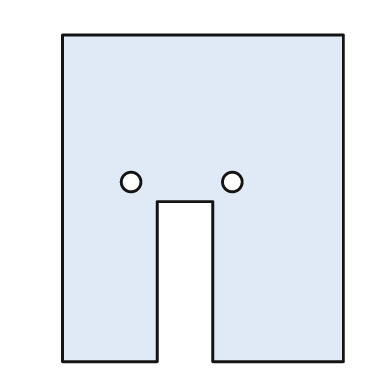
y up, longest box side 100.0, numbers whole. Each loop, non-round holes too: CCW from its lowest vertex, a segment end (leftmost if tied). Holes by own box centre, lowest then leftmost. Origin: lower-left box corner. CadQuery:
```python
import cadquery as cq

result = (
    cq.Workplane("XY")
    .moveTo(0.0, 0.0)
    .lineTo(29.0, 0.0)
    .lineTo(29.0, 49.0)
    .lineTo(46.0, 49.0)
    .lineTo(46.0, 0.0)
    .lineTo(86.0, 0.0)
    .lineTo(86.0, 100.0)
    .lineTo(0.0, 100.0)
    .close()
    .moveTo(21.0, 55.0)
    .circle(3.0)
    .moveTo(52.0, 55.0)
    .circle(3.0)
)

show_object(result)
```